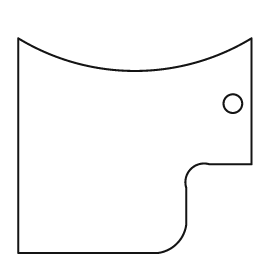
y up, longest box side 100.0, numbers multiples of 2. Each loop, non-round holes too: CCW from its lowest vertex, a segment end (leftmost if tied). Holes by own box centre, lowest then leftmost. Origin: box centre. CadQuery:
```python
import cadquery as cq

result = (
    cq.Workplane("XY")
    .moveTo(-50.0, -46.0)
    .lineTo(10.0, -46.0)
    .threePointArc((18.0, -42.0), (22.0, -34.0))
    .lineTo(22.0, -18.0)
    .threePointArc((24.0, -10.0), (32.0, -8.0))
    .lineTo(50.0, -8.0)
    .lineTo(50.0, 46.0)
    .threePointArc((0.0, 32.0), (-50.0, 46.0))
    .close()
    .moveTo(42.0, 18.0)
    .circle(4.0)
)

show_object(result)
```